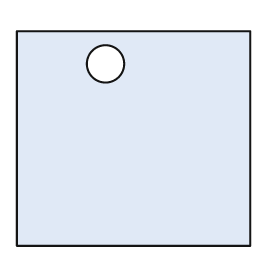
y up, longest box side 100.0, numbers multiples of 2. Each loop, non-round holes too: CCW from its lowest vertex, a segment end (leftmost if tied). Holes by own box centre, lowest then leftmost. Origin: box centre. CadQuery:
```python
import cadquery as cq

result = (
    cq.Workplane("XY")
    .moveTo(-50.0, -46.0)
    .lineTo(50.0, -46.0)
    .lineTo(50.0, 46.0)
    .lineTo(-50.0, 46.0)
    .close()
    .moveTo(-12.0, 32.0)
    .circle(8.0)
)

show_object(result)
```